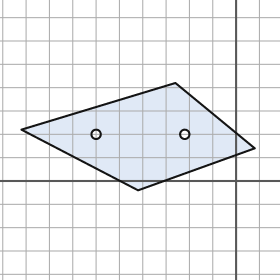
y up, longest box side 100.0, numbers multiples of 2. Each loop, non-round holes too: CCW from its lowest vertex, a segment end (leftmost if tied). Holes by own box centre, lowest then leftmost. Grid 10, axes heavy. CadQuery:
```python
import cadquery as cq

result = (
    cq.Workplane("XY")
    .moveTo(-42.0, -4.0)
    .lineTo(8.0, 14.0)
    .lineTo(-26.0, 42.0)
    .lineTo(-92.0, 22.0)
    .close()
    .moveTo(-60.0, 20.0)
    .circle(2.0)
    .moveTo(-22.0, 20.0)
    .circle(2.0)
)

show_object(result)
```